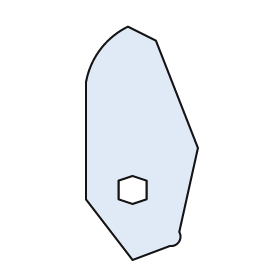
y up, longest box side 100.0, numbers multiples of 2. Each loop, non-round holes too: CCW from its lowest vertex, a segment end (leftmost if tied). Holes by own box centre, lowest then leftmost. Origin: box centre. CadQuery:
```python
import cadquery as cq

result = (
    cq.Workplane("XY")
    .moveTo(-4.0, -50.0)
    .lineTo(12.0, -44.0)
    .threePointArc((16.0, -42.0), (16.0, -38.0))
    .lineTo(24.0, -2.0)
    .lineTo(6.0, 44.0)
    .lineTo(-6.0, 50.0)
    .threePointArc((-18.0, 40.0), (-24.0, 26.0))
    .lineTo(-24.0, -24.0)
    .close()
    .moveTo(-4.0, -26.0)
    .lineTo(2.0, -24.0)
    .lineTo(2.0, -16.0)
    .lineTo(-4.0, -14.0)
    .lineTo(-10.0, -16.0)
    .lineTo(-10.0, -24.0)
    .close()
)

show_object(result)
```